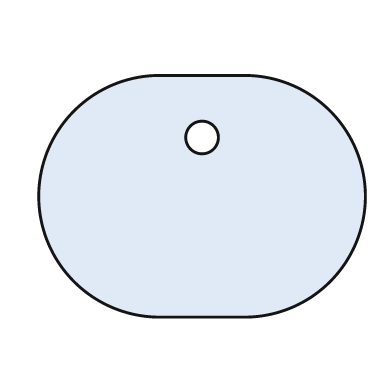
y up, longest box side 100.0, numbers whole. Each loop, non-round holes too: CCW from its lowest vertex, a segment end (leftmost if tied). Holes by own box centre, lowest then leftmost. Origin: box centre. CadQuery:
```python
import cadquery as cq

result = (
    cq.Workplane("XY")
    .moveTo(-13.0, -37.0)
    .lineTo(13.0, -37.0)
    .threePointArc((50.0, 0.0), (13.0, 37.0))
    .lineTo(-13.0, 37.0)
    .threePointArc((-50.0, 0.0), (-13.0, -37.0))
    .close()
    .moveTo(0.0, 18.0)
    .circle(5.0)
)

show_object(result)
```